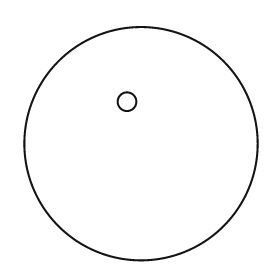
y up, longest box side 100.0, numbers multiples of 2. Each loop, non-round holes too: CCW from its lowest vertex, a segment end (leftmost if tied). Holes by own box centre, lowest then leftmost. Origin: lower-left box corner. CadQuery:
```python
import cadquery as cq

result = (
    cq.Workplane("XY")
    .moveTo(50.0, 50.0)
    .circle(50.0)
    .moveTo(44.0, 68.0)
    .circle(4.0)
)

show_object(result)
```